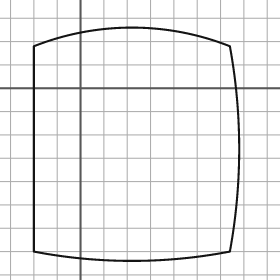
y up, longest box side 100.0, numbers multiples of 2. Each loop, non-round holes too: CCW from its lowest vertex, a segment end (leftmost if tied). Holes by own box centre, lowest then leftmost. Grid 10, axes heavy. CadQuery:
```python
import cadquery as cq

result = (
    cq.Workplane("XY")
    .moveTo(-20.0, -70.0)
    .threePointArc((22.0, -74.0), (64.0, -70.0))
    .threePointArc((68.0, -26.0), (64.0, 18.0))
    .threePointArc((22.0, 26.0), (-20.0, 18.0))
    .close()
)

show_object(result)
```